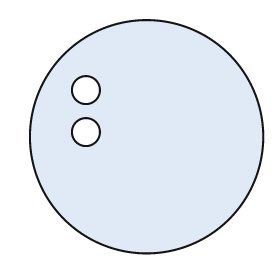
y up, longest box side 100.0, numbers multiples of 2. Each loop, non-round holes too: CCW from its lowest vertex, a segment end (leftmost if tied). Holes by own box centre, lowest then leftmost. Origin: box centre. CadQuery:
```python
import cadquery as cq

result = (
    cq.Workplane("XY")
    .moveTo(0.0, 0.0)
    .circle(50.0)
    .moveTo(-26.0, 2.0)
    .circle(6.0)
    .moveTo(-26.0, 20.0)
    .circle(6.0)
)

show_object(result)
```